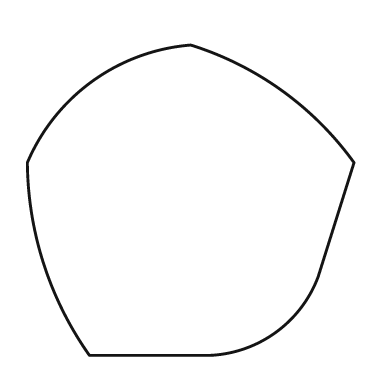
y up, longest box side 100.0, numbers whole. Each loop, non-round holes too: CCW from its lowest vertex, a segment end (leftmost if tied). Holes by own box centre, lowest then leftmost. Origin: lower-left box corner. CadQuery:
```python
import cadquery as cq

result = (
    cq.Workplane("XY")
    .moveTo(19.0, 0.0)
    .lineTo(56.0, 0.0)
    .threePointArc((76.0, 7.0), (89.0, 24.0))
    .lineTo(100.0, 59.0)
    .threePointArc((78.0, 81.0), (50.0, 95.0))
    .threePointArc((20.0, 84.0), (0.0, 59.0))
    .threePointArc((5.0, 28.0), (19.0, 0.0))
    .close()
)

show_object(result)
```